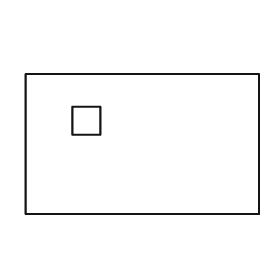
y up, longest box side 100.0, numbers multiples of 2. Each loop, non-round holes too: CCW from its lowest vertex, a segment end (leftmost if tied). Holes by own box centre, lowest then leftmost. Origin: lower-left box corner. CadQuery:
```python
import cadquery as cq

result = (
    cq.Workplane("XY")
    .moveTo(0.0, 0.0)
    .lineTo(100.0, 0.0)
    .lineTo(100.0, 60.0)
    .lineTo(0.0, 60.0)
    .close()
    .moveTo(20.0, 34.0)
    .lineTo(32.0, 34.0)
    .lineTo(32.0, 46.0)
    .lineTo(20.0, 46.0)
    .close()
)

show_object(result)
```